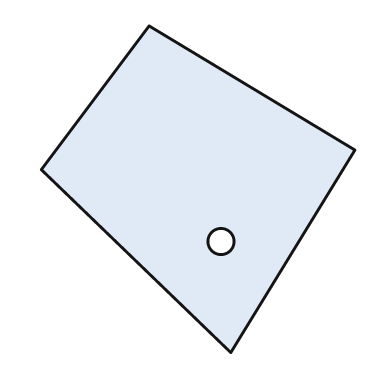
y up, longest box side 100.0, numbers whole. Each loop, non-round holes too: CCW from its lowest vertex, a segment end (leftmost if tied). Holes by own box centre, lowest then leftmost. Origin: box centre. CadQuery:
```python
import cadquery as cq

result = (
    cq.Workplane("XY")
    .moveTo(10.0, -50.0)
    .lineTo(48.0, 12.0)
    .lineTo(-15.0, 50.0)
    .lineTo(-48.0, 6.0)
    .close()
    .moveTo(7.0, -16.0)
    .circle(4.0)
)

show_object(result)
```